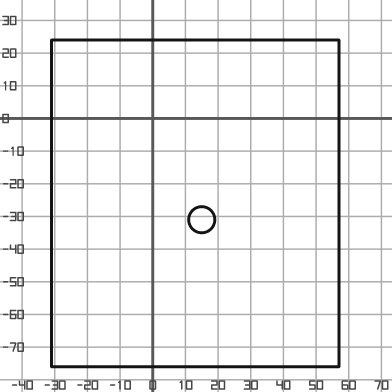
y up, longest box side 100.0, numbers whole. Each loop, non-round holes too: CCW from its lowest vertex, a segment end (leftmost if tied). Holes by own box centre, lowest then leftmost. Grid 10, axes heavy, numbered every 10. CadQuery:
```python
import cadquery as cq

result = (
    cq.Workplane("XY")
    .moveTo(-31.0, -76.0)
    .lineTo(57.0, -76.0)
    .lineTo(57.0, 24.0)
    .lineTo(-31.0, 24.0)
    .close()
    .moveTo(15.0, -31.0)
    .circle(4.0)
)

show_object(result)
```